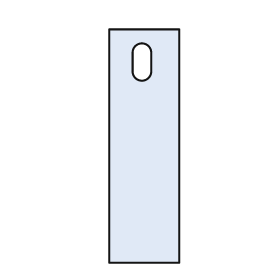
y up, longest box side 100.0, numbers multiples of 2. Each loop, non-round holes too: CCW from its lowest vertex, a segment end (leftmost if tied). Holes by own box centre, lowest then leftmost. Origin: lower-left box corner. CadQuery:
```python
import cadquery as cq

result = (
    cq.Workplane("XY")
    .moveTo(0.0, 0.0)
    .lineTo(30.0, 0.0)
    .lineTo(30.0, 100.0)
    .lineTo(0.0, 100.0)
    .close()
    .moveTo(10.0, 82.0)
    .threePointArc((14.0, 78.0), (18.0, 82.0))
    .lineTo(18.0, 90.0)
    .threePointArc((14.0, 94.0), (10.0, 90.0))
    .close()
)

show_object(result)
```